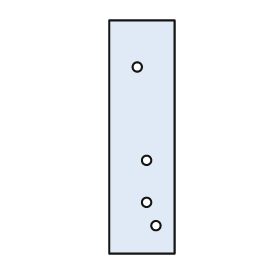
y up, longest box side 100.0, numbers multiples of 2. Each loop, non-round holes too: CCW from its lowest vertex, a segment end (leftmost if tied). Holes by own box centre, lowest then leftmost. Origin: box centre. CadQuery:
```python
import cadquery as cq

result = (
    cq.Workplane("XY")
    .moveTo(-14.0, -50.0)
    .lineTo(14.0, -50.0)
    .lineTo(14.0, 50.0)
    .lineTo(-14.0, 50.0)
    .close()
    .moveTo(6.0, -38.0)
    .circle(2.0)
    .moveTo(2.0, -28.0)
    .circle(2.0)
    .moveTo(2.0, -10.0)
    .circle(2.0)
    .moveTo(-2.0, 30.0)
    .circle(2.0)
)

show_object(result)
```